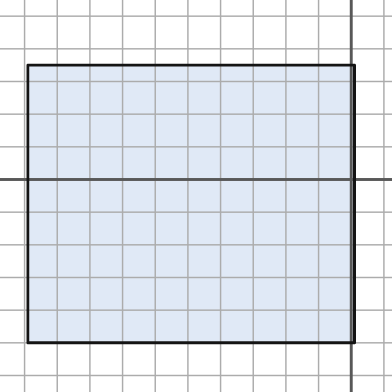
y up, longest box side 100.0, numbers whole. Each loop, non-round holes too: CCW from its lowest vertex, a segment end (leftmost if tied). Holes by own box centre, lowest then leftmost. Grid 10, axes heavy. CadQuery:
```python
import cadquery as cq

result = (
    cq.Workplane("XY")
    .moveTo(-99.0, -50.0)
    .lineTo(1.0, -50.0)
    .lineTo(1.0, 35.0)
    .lineTo(-99.0, 35.0)
    .close()
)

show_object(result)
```